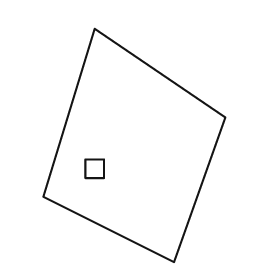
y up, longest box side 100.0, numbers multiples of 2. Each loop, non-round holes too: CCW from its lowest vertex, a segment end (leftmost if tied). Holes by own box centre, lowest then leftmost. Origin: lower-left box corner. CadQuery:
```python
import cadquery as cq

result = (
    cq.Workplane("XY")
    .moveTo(56.0, 0.0)
    .lineTo(78.0, 62.0)
    .lineTo(22.0, 100.0)
    .lineTo(0.0, 28.0)
    .close()
    .moveTo(18.0, 36.0)
    .lineTo(26.0, 36.0)
    .lineTo(26.0, 44.0)
    .lineTo(18.0, 44.0)
    .close()
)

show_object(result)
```